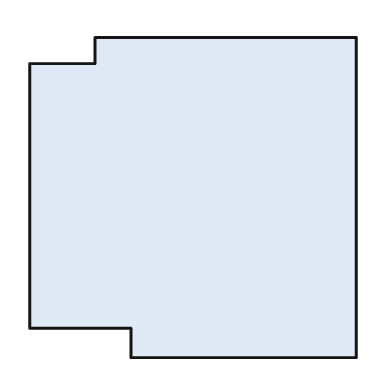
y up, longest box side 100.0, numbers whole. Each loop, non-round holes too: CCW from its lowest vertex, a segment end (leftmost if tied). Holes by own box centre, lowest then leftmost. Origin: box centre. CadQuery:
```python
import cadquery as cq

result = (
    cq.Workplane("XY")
    .moveTo(-19.0, -49.0)
    .lineTo(50.0, -49.0)
    .lineTo(50.0, 49.0)
    .lineTo(-30.0, 49.0)
    .lineTo(-30.0, 41.0)
    .lineTo(-50.0, 41.0)
    .lineTo(-50.0, -40.0)
    .lineTo(-19.0, -40.0)
    .close()
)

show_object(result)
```